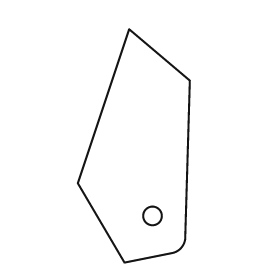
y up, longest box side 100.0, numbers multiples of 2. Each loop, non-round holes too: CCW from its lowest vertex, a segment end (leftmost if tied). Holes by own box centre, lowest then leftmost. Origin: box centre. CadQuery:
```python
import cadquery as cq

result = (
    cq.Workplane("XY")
    .moveTo(-4.0, -50.0)
    .lineTo(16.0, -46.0)
    .threePointArc((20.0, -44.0), (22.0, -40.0))
    .lineTo(24.0, 28.0)
    .lineTo(-2.0, 50.0)
    .lineTo(-24.0, -16.0)
    .close()
    .moveTo(8.0, -30.0)
    .circle(4.0)
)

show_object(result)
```